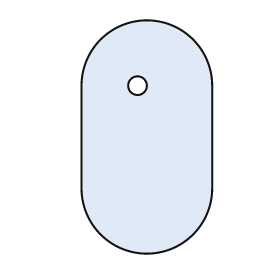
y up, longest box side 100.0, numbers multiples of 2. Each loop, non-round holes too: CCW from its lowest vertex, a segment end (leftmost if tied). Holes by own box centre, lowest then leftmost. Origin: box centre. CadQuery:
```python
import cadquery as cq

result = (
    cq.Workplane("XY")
    .moveTo(-28.0, -22.0)
    .threePointArc((0.0, -50.0), (28.0, -22.0))
    .lineTo(28.0, 22.0)
    .threePointArc((0.0, 50.0), (-28.0, 22.0))
    .close()
    .moveTo(-4.0, 22.0)
    .circle(4.0)
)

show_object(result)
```